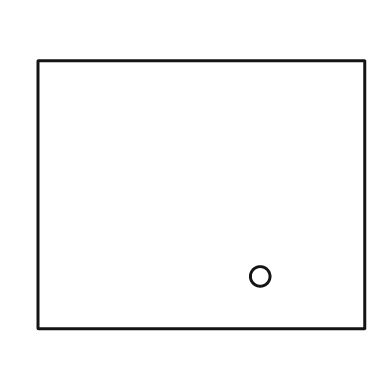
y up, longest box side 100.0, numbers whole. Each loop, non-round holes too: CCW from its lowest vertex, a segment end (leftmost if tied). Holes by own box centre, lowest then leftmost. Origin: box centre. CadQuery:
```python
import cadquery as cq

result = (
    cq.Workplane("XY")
    .moveTo(-50.0, -41.0)
    .lineTo(50.0, -41.0)
    .lineTo(50.0, 41.0)
    .lineTo(-50.0, 41.0)
    .close()
    .moveTo(18.0, -25.0)
    .circle(3.0)
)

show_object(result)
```